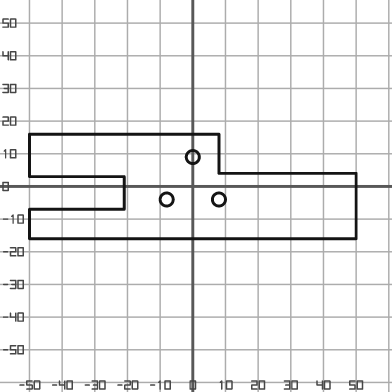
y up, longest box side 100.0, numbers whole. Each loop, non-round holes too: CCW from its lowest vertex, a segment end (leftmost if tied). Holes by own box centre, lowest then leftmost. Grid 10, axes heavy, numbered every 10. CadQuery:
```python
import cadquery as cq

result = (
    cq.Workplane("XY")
    .moveTo(-50.0, -16.0)
    .lineTo(50.0, -16.0)
    .lineTo(50.0, 4.0)
    .lineTo(8.0, 4.0)
    .lineTo(8.0, 16.0)
    .lineTo(-50.0, 16.0)
    .lineTo(-50.0, 3.0)
    .lineTo(-21.0, 3.0)
    .lineTo(-21.0, -7.0)
    .lineTo(-50.0, -7.0)
    .close()
    .moveTo(-8.0, -4.0)
    .circle(2.0)
    .moveTo(8.0, -4.0)
    .circle(2.0)
    .moveTo(0.0, 9.0)
    .circle(2.0)
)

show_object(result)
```